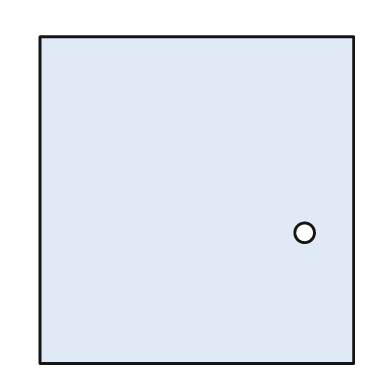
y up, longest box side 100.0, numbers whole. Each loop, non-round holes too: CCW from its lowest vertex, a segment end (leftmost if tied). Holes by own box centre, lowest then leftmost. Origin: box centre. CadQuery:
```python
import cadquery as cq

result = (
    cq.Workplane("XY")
    .moveTo(-48.0, -50.0)
    .lineTo(48.0, -50.0)
    .lineTo(48.0, 50.0)
    .lineTo(-48.0, 50.0)
    .close()
    .moveTo(33.0, -10.0)
    .circle(3.0)
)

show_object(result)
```